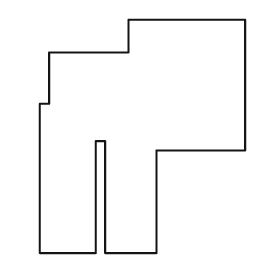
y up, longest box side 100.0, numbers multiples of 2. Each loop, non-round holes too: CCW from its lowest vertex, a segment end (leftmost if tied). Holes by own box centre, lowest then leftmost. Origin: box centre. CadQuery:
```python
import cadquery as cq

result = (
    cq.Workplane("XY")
    .moveTo(-44.0, -50.0)
    .lineTo(-20.0, -50.0)
    .lineTo(-20.0, -2.0)
    .lineTo(-16.0, -2.0)
    .lineTo(-16.0, -50.0)
    .lineTo(6.0, -50.0)
    .lineTo(6.0, -6.0)
    .lineTo(44.0, -6.0)
    .lineTo(44.0, 50.0)
    .lineTo(-6.0, 50.0)
    .lineTo(-6.0, 36.0)
    .lineTo(-40.0, 36.0)
    .lineTo(-40.0, 14.0)
    .lineTo(-44.0, 14.0)
    .close()
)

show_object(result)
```